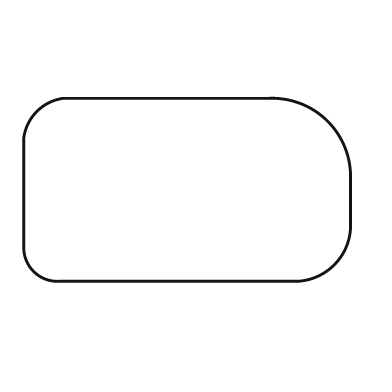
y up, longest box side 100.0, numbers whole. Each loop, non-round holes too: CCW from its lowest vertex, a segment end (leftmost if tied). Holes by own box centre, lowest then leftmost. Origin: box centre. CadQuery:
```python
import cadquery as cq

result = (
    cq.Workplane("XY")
    .moveTo(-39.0, -28.0)
    .lineTo(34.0, -28.0)
    .threePointArc((45.0, -23.0), (50.0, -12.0))
    .lineTo(50.0, 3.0)
    .threePointArc((43.0, 21.0), (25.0, 28.0))
    .lineTo(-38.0, 28.0)
    .threePointArc((-46.0, 24.0), (-50.0, 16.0))
    .lineTo(-50.0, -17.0)
    .threePointArc((-47.0, -25.0), (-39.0, -28.0))
    .close()
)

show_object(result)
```